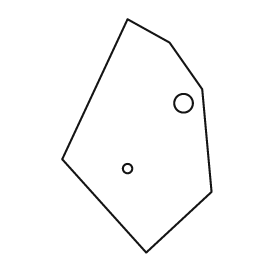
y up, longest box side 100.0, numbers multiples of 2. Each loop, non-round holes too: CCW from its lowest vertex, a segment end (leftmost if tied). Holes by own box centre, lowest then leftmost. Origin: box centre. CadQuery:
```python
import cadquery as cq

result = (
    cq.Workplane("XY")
    .moveTo(4.0, -50.0)
    .lineTo(32.0, -24.0)
    .lineTo(28.0, 20.0)
    .lineTo(14.0, 40.0)
    .lineTo(-4.0, 50.0)
    .lineTo(-32.0, -10.0)
    .close()
    .moveTo(-4.0, -14.0)
    .circle(2.0)
    .moveTo(20.0, 14.0)
    .circle(4.0)
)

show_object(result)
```